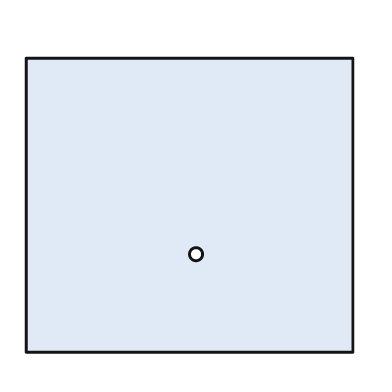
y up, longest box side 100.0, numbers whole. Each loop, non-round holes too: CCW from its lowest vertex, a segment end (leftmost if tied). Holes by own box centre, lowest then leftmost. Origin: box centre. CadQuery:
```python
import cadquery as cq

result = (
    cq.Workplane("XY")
    .moveTo(-50.0, -45.0)
    .lineTo(50.0, -45.0)
    .lineTo(50.0, 45.0)
    .lineTo(-50.0, 45.0)
    .close()
    .moveTo(2.0, -15.0)
    .circle(2.0)
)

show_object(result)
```